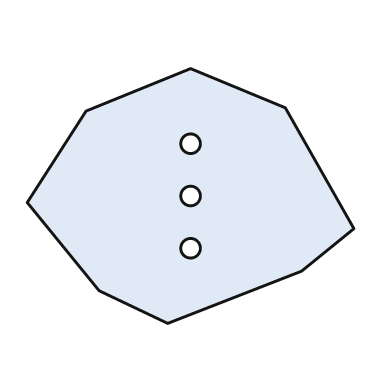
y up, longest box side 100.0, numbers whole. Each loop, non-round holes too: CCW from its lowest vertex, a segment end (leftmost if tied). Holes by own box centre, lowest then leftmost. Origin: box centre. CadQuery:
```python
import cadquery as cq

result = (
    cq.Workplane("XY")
    .moveTo(-7.0, -39.0)
    .lineTo(34.0, -23.0)
    .lineTo(50.0, -10.0)
    .lineTo(29.0, 27.0)
    .lineTo(0.0, 39.0)
    .lineTo(-32.0, 26.0)
    .lineTo(-50.0, -2.0)
    .lineTo(-28.0, -29.0)
    .close()
    .moveTo(0.0, -16.0)
    .circle(3.0)
    .moveTo(0.0, 0.0)
    .circle(3.0)
    .moveTo(0.0, 16.0)
    .circle(3.0)
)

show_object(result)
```